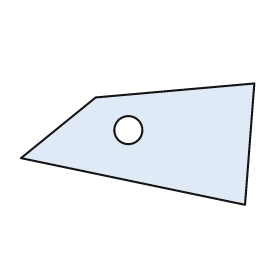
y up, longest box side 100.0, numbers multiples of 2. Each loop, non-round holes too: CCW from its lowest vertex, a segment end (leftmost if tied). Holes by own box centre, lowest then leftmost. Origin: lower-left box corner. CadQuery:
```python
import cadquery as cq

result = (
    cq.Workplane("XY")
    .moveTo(96.0, 0.0)
    .lineTo(100.0, 52.0)
    .lineTo(32.0, 46.0)
    .lineTo(0.0, 20.0)
    .close()
    .moveTo(46.0, 32.0)
    .circle(6.0)
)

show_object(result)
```